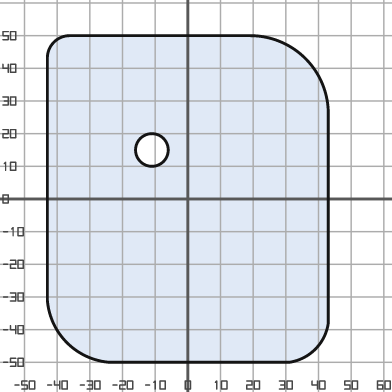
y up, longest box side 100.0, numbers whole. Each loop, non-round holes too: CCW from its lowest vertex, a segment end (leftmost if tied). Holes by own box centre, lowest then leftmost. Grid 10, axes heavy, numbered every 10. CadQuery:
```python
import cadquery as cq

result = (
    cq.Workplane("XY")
    .moveTo(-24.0, -50.0)
    .lineTo(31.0, -50.0)
    .threePointArc((39.0, -46.0), (43.0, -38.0))
    .lineTo(43.0, 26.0)
    .threePointArc((36.0, 43.0), (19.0, 50.0))
    .lineTo(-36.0, 50.0)
    .threePointArc((-41.0, 48.0), (-43.0, 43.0))
    .lineTo(-43.0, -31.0)
    .threePointArc((-37.0, -44.0), (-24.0, -50.0))
    .close()
    .moveTo(-11.0, 15.0)
    .circle(5.0)
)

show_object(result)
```